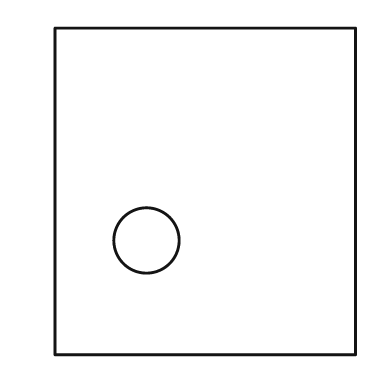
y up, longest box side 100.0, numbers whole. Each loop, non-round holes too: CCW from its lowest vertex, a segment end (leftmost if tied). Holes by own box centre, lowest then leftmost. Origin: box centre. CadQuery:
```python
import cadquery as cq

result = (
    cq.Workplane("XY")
    .moveTo(-46.0, -50.0)
    .lineTo(46.0, -50.0)
    .lineTo(46.0, 50.0)
    .lineTo(-46.0, 50.0)
    .close()
    .moveTo(-18.0, -15.0)
    .circle(10.0)
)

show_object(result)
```